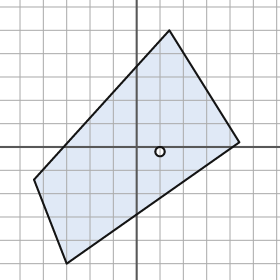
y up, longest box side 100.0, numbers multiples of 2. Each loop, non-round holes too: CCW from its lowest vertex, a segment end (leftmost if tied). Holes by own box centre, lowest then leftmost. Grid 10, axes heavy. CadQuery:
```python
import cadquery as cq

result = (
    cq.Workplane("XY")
    .moveTo(-30.0, -50.0)
    .lineTo(44.0, 2.0)
    .lineTo(14.0, 50.0)
    .lineTo(-44.0, -14.0)
    .close()
    .moveTo(10.0, -2.0)
    .circle(2.0)
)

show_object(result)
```